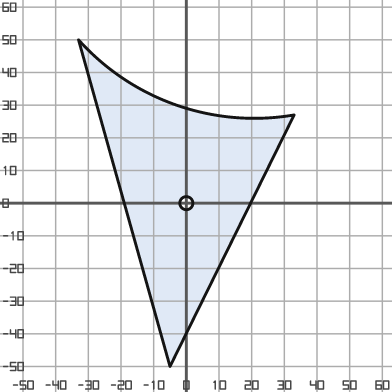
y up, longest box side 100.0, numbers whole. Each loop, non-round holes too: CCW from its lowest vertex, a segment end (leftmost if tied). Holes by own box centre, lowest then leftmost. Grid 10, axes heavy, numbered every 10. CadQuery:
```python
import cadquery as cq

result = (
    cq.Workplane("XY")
    .moveTo(-5.0, -50.0)
    .lineTo(33.0, 27.0)
    .threePointArc((-3.0, 30.0), (-33.0, 50.0))
    .close()
    .moveTo(0.0, 0.0)
    .circle(2.0)
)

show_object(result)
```